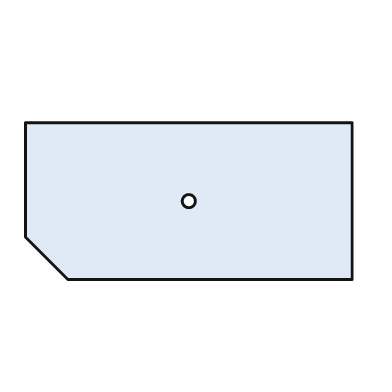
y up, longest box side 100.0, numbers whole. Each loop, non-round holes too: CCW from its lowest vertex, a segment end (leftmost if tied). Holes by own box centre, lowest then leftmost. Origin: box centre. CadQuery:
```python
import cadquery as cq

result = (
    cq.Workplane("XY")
    .moveTo(-37.0, -24.0)
    .lineTo(50.0, -24.0)
    .lineTo(50.0, 24.0)
    .lineTo(-50.0, 24.0)
    .lineTo(-50.0, -11.0)
    .close()
    .moveTo(0.0, 0.0)
    .circle(2.0)
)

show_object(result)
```